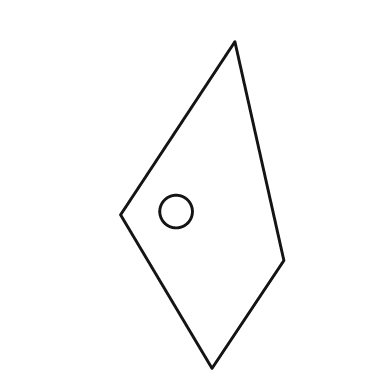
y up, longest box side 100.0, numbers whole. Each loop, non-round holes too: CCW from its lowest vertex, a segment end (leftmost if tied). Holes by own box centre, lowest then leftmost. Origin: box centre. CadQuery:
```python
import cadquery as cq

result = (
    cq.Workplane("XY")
    .moveTo(3.0, -50.0)
    .lineTo(25.0, -17.0)
    .lineTo(10.0, 50.0)
    .lineTo(-25.0, -3.0)
    .close()
    .moveTo(-8.0, -2.0)
    .circle(5.0)
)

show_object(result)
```